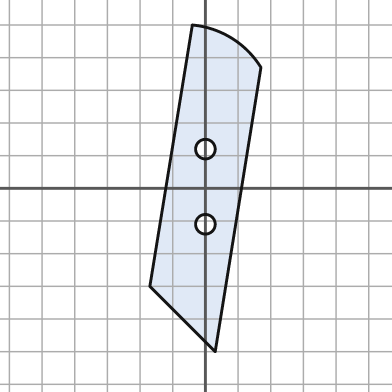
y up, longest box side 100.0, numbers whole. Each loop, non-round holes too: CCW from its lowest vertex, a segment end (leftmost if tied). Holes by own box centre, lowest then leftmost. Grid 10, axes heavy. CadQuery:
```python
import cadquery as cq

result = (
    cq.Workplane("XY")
    .moveTo(3.0, -50.0)
    .lineTo(17.0, 37.0)
    .threePointArc((8.0, 46.0), (-4.0, 50.0))
    .lineTo(-17.0, -30.0)
    .close()
    .moveTo(0.0, -11.0)
    .circle(3.0)
    .moveTo(0.0, 12.0)
    .circle(3.0)
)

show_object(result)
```